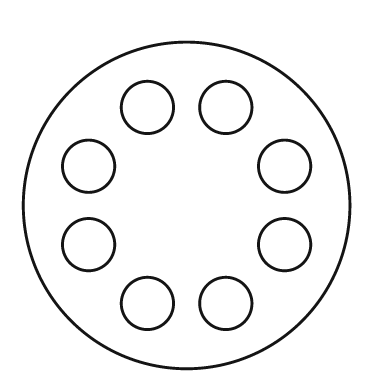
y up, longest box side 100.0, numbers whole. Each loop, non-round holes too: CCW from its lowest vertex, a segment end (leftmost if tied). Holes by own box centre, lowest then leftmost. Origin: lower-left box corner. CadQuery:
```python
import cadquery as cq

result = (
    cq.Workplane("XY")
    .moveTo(50.0, 50.0)
    .circle(50.0)
    .moveTo(38.0, 20.0)
    .circle(8.0)
    .moveTo(62.0, 20.0)
    .circle(8.0)
    .moveTo(20.0, 38.0)
    .circle(8.0)
    .moveTo(80.0, 38.0)
    .circle(8.0)
    .moveTo(20.0, 62.0)
    .circle(8.0)
    .moveTo(80.0, 62.0)
    .circle(8.0)
    .moveTo(38.0, 80.0)
    .circle(8.0)
    .moveTo(62.0, 80.0)
    .circle(8.0)
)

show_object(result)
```